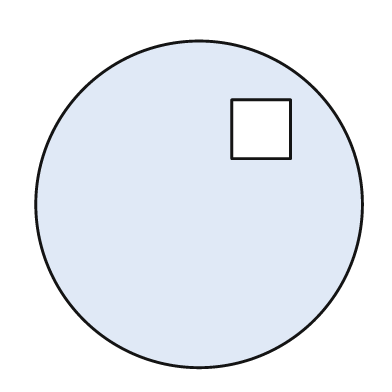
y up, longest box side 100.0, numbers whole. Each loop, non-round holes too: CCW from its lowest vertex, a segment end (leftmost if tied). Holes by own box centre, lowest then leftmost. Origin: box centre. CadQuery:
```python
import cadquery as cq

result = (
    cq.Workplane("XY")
    .moveTo(0.0, 0.0)
    .circle(50.0)
    .moveTo(10.0, 14.0)
    .lineTo(28.0, 14.0)
    .lineTo(28.0, 32.0)
    .lineTo(10.0, 32.0)
    .close()
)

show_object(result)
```